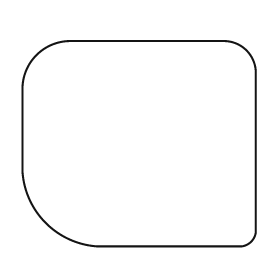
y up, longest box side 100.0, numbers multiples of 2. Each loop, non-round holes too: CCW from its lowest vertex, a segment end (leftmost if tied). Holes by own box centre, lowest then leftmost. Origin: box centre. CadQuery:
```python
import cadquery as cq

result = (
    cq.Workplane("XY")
    .moveTo(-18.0, -44.0)
    .lineTo(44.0, -44.0)
    .threePointArc((48.0, -42.0), (50.0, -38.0))
    .lineTo(50.0, 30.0)
    .threePointArc((46.0, 40.0), (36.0, 44.0))
    .lineTo(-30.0, 44.0)
    .threePointArc((-44.0, 38.0), (-50.0, 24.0))
    .lineTo(-50.0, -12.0)
    .threePointArc((-40.0, -34.0), (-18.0, -44.0))
    .close()
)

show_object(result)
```